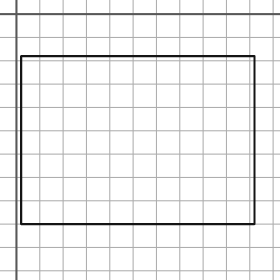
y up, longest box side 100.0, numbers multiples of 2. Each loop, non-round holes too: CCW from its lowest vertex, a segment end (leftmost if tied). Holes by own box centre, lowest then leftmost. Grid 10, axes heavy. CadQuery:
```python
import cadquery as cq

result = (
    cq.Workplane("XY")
    .moveTo(2.0, -90.0)
    .lineTo(102.0, -90.0)
    .lineTo(102.0, -18.0)
    .lineTo(2.0, -18.0)
    .close()
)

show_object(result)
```